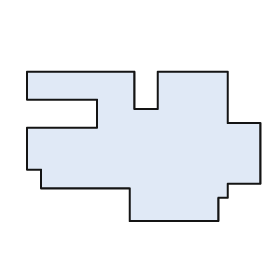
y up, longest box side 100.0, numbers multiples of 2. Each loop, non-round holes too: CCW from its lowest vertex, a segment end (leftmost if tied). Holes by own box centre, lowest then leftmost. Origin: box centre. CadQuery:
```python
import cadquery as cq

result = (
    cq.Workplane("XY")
    .moveTo(-6.0, -32.0)
    .lineTo(32.0, -32.0)
    .lineTo(32.0, -22.0)
    .lineTo(36.0, -22.0)
    .lineTo(36.0, -16.0)
    .lineTo(50.0, -16.0)
    .lineTo(50.0, 10.0)
    .lineTo(36.0, 10.0)
    .lineTo(36.0, 32.0)
    .lineTo(6.0, 32.0)
    .lineTo(6.0, 16.0)
    .lineTo(-4.0, 16.0)
    .lineTo(-4.0, 32.0)
    .lineTo(-50.0, 32.0)
    .lineTo(-50.0, 20.0)
    .lineTo(-20.0, 20.0)
    .lineTo(-20.0, 8.0)
    .lineTo(-50.0, 8.0)
    .lineTo(-50.0, -10.0)
    .lineTo(-44.0, -10.0)
    .lineTo(-44.0, -18.0)
    .lineTo(-6.0, -18.0)
    .close()
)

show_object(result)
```